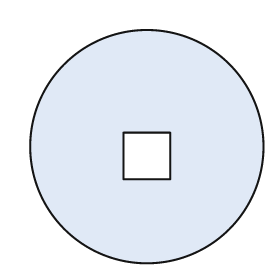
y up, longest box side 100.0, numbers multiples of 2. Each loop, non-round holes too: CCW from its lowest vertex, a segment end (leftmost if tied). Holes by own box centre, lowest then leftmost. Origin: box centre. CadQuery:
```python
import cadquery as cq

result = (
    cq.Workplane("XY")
    .moveTo(0.0, 0.0)
    .circle(50.0)
    .moveTo(-10.0, -14.0)
    .lineTo(10.0, -14.0)
    .lineTo(10.0, 6.0)
    .lineTo(-10.0, 6.0)
    .close()
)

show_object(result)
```